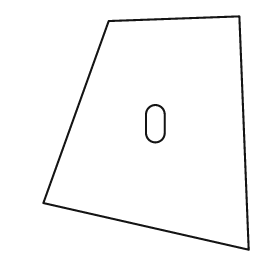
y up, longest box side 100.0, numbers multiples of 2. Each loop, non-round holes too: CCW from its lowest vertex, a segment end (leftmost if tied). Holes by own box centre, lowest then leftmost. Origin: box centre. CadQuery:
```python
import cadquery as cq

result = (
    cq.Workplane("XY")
    .moveTo(44.0, -50.0)
    .lineTo(40.0, 50.0)
    .lineTo(-16.0, 48.0)
    .lineTo(-44.0, -30.0)
    .close()
    .moveTo(0.0, 0.0)
    .threePointArc((4.0, -4.0), (8.0, 0.0))
    .lineTo(8.0, 8.0)
    .threePointArc((4.0, 12.0), (0.0, 8.0))
    .close()
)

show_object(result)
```